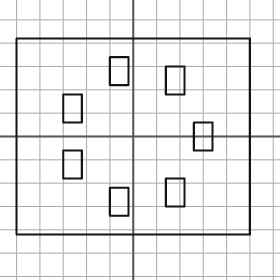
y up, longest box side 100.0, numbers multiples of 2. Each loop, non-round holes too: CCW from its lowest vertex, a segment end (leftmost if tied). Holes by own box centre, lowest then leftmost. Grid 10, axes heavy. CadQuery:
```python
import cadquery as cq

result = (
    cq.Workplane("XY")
    .moveTo(-50.0, -42.0)
    .lineTo(50.0, -42.0)
    .lineTo(50.0, 42.0)
    .lineTo(-50.0, 42.0)
    .close()
    .moveTo(-10.0, -34.0)
    .lineTo(-2.0, -34.0)
    .lineTo(-2.0, -22.0)
    .lineTo(-10.0, -22.0)
    .close()
    .moveTo(14.0, -30.0)
    .lineTo(22.0, -30.0)
    .lineTo(22.0, -18.0)
    .lineTo(14.0, -18.0)
    .close()
    .moveTo(-30.0, -18.0)
    .lineTo(-22.0, -18.0)
    .lineTo(-22.0, -6.0)
    .lineTo(-30.0, -6.0)
    .close()
    .moveTo(26.0, -6.0)
    .lineTo(34.0, -6.0)
    .lineTo(34.0, 6.0)
    .lineTo(26.0, 6.0)
    .close()
    .moveTo(-30.0, 6.0)
    .lineTo(-22.0, 6.0)
    .lineTo(-22.0, 18.0)
    .lineTo(-30.0, 18.0)
    .close()
    .moveTo(14.0, 18.0)
    .lineTo(22.0, 18.0)
    .lineTo(22.0, 30.0)
    .lineTo(14.0, 30.0)
    .close()
    .moveTo(-10.0, 22.0)
    .lineTo(-2.0, 22.0)
    .lineTo(-2.0, 34.0)
    .lineTo(-10.0, 34.0)
    .close()
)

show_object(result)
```